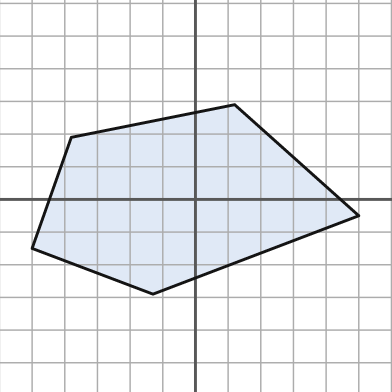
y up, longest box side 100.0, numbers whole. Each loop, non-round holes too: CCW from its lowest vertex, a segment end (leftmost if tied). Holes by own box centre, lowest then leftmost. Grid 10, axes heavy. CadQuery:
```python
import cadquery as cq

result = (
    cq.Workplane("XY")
    .moveTo(-13.0, -29.0)
    .lineTo(50.0, -5.0)
    .lineTo(12.0, 29.0)
    .lineTo(-38.0, 19.0)
    .lineTo(-50.0, -15.0)
    .close()
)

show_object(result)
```